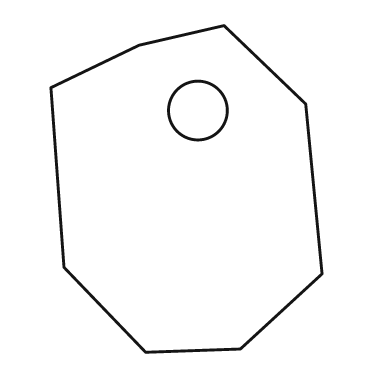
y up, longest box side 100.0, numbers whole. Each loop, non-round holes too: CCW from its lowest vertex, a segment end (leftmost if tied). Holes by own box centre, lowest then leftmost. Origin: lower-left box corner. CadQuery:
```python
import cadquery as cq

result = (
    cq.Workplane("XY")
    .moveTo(29.0, 0.0)
    .lineTo(58.0, 1.0)
    .lineTo(83.0, 24.0)
    .lineTo(78.0, 76.0)
    .lineTo(53.0, 100.0)
    .lineTo(27.0, 94.0)
    .lineTo(0.0, 81.0)
    .lineTo(4.0, 26.0)
    .close()
    .moveTo(45.0, 74.0)
    .circle(9.0)
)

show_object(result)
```